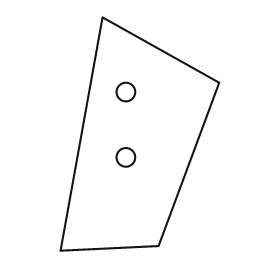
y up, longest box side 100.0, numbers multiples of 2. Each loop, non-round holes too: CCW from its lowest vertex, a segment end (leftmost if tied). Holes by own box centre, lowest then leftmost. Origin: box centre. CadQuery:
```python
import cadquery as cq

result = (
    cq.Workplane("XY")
    .moveTo(-34.0, -50.0)
    .lineTo(8.0, -48.0)
    .lineTo(34.0, 22.0)
    .lineTo(-16.0, 50.0)
    .close()
    .moveTo(-6.0, -10.0)
    .circle(4.0)
    .moveTo(-6.0, 18.0)
    .circle(4.0)
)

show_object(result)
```